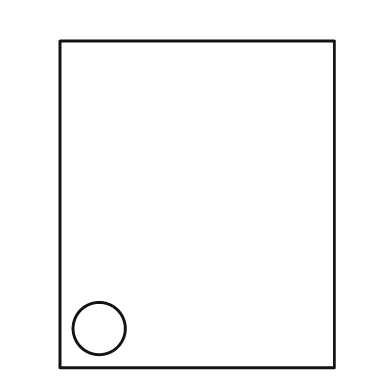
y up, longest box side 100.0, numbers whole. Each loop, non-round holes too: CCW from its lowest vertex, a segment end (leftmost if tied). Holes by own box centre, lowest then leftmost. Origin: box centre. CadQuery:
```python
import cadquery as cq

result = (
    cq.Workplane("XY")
    .moveTo(-42.0, -50.0)
    .lineTo(42.0, -50.0)
    .lineTo(42.0, 50.0)
    .lineTo(-42.0, 50.0)
    .close()
    .moveTo(-30.0, -38.0)
    .circle(8.0)
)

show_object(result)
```